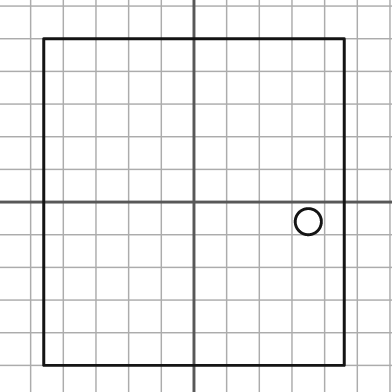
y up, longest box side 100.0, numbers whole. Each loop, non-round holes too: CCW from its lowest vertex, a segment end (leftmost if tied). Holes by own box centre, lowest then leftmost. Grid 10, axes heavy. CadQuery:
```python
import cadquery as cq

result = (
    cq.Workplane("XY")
    .moveTo(-46.0, -50.0)
    .lineTo(46.0, -50.0)
    .lineTo(46.0, 50.0)
    .lineTo(-46.0, 50.0)
    .close()
    .moveTo(35.0, -6.0)
    .circle(4.0)
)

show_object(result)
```